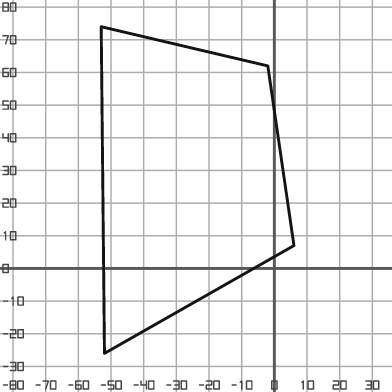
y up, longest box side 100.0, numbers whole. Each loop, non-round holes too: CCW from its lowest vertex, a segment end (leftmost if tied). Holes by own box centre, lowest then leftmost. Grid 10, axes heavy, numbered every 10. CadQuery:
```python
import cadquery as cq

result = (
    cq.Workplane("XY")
    .moveTo(-52.0, -26.0)
    .lineTo(6.0, 7.0)
    .lineTo(-2.0, 62.0)
    .lineTo(-53.0, 74.0)
    .close()
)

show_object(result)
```